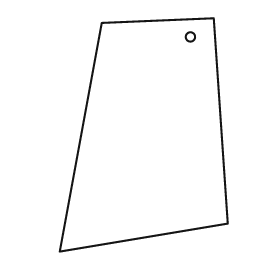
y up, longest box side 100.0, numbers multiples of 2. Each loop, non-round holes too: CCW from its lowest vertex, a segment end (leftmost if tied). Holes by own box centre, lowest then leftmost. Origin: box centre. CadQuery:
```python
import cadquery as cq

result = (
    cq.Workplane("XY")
    .moveTo(-36.0, -50.0)
    .lineTo(36.0, -38.0)
    .lineTo(30.0, 50.0)
    .lineTo(-18.0, 48.0)
    .close()
    .moveTo(20.0, 42.0)
    .circle(2.0)
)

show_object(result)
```